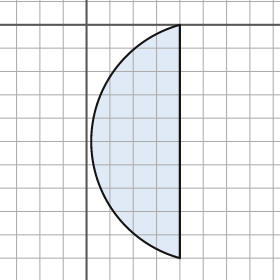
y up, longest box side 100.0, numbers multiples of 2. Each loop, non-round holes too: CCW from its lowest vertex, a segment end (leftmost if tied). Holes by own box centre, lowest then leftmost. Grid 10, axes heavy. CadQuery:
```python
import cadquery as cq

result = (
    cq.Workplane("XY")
    .moveTo(40.0, -100.0)
    .lineTo(40.0, 0.0)
    .threePointArc((2.0, -50.0), (40.0, -100.0))
    .close()
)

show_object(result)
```